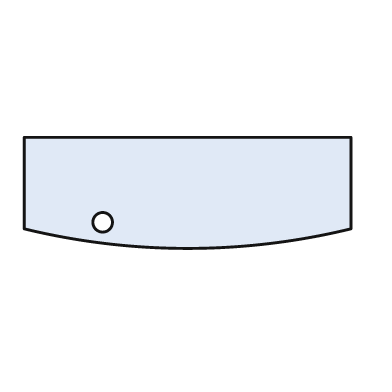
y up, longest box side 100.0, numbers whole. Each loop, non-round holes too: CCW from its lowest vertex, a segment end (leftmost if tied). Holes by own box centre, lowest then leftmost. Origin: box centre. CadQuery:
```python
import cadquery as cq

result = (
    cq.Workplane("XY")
    .moveTo(-50.0, -11.0)
    .threePointArc((0.0, -17.0), (50.0, -11.0))
    .lineTo(50.0, 17.0)
    .lineTo(-50.0, 17.0)
    .close()
    .moveTo(-26.0, -9.0)
    .circle(3.0)
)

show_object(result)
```